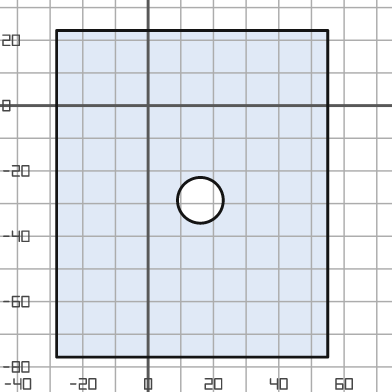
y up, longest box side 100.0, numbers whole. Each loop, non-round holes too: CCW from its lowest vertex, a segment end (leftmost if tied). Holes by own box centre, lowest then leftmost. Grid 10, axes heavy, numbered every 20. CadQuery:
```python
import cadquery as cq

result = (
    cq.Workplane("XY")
    .moveTo(-28.0, -77.0)
    .lineTo(55.0, -77.0)
    .lineTo(55.0, 23.0)
    .lineTo(-28.0, 23.0)
    .close()
    .moveTo(16.0, -29.0)
    .circle(7.0)
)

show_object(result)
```